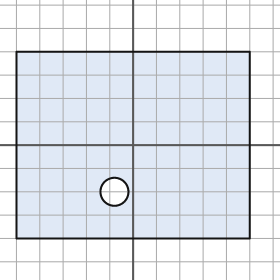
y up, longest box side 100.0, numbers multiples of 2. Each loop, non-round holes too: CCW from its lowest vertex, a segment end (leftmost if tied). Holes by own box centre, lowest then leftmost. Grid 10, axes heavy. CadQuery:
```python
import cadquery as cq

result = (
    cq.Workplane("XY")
    .moveTo(-50.0, -40.0)
    .lineTo(50.0, -40.0)
    .lineTo(50.0, 40.0)
    .lineTo(-50.0, 40.0)
    .close()
    .moveTo(-8.0, -20.0)
    .circle(6.0)
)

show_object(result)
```